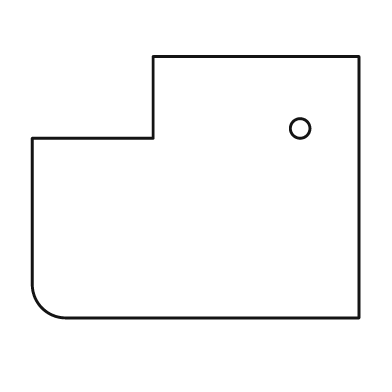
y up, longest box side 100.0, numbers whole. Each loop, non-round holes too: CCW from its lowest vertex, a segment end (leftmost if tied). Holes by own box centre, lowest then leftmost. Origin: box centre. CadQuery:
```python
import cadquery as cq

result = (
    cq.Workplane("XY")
    .moveTo(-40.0, -40.0)
    .lineTo(50.0, -40.0)
    .lineTo(50.0, 40.0)
    .lineTo(-13.0, 40.0)
    .lineTo(-13.0, 15.0)
    .lineTo(-50.0, 15.0)
    .lineTo(-50.0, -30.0)
    .threePointArc((-47.0, -37.0), (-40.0, -40.0))
    .close()
    .moveTo(32.0, 18.0)
    .circle(3.0)
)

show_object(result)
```